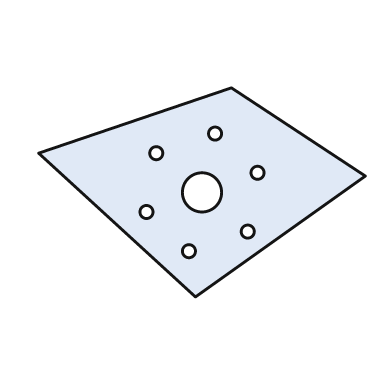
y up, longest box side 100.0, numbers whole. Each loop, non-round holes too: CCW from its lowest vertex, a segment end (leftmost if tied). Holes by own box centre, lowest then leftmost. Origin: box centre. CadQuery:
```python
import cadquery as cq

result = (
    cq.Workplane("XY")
    .moveTo(-2.0, -32.0)
    .lineTo(50.0, 5.0)
    .lineTo(9.0, 32.0)
    .lineTo(-50.0, 12.0)
    .close()
    .moveTo(-4.0, -18.0)
    .circle(2.0)
    .moveTo(14.0, -12.0)
    .circle(2.0)
    .moveTo(-17.0, -6.0)
    .circle(2.0)
    .moveTo(0.0, 0.0)
    .circle(6.0)
    .moveTo(17.0, 6.0)
    .circle(2.0)
    .moveTo(-14.0, 12.0)
    .circle(2.0)
    .moveTo(4.0, 18.0)
    .circle(2.0)
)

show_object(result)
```